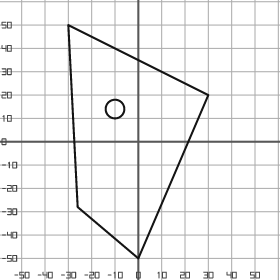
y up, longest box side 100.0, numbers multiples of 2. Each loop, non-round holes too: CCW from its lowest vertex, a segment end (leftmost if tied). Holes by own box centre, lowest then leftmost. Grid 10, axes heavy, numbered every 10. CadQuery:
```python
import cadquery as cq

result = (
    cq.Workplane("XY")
    .moveTo(0.0, -50.0)
    .lineTo(30.0, 20.0)
    .lineTo(-30.0, 50.0)
    .lineTo(-26.0, -28.0)
    .close()
    .moveTo(-10.0, 14.0)
    .circle(4.0)
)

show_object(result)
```